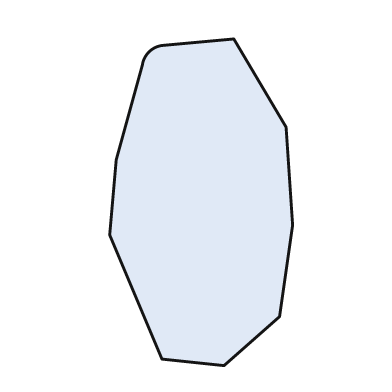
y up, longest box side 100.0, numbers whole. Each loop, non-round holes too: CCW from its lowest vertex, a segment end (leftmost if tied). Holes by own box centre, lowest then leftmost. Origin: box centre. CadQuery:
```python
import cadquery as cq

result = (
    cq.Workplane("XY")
    .moveTo(7.0, -50.0)
    .lineTo(24.0, -35.0)
    .lineTo(28.0, -7.0)
    .lineTo(26.0, 23.0)
    .lineTo(10.0, 50.0)
    .lineTo(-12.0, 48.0)
    .threePointArc((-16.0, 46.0), (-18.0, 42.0))
    .lineTo(-26.0, 13.0)
    .lineTo(-28.0, -10.0)
    .lineTo(-12.0, -48.0)
    .close()
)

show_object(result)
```